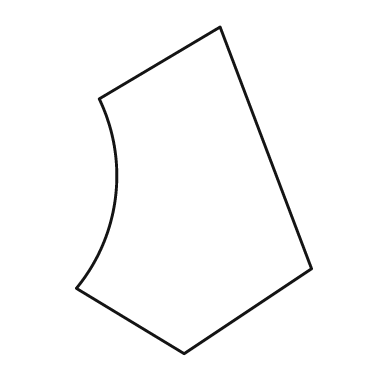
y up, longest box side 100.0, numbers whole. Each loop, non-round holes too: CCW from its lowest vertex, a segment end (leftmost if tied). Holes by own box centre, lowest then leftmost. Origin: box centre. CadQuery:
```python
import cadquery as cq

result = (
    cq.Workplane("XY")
    .moveTo(-3.0, -50.0)
    .lineTo(36.0, -24.0)
    .lineTo(8.0, 50.0)
    .lineTo(-29.0, 28.0)
    .threePointArc((-24.0, -2.0), (-36.0, -30.0))
    .close()
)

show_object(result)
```